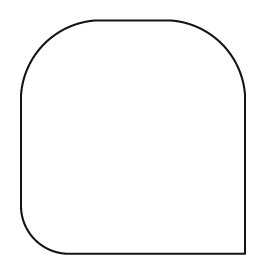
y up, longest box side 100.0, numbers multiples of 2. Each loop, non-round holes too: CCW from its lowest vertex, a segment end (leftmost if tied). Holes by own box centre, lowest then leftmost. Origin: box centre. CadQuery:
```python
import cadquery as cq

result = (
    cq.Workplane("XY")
    .moveTo(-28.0, -50.0)
    .lineTo(48.0, -50.0)
    .lineTo(48.0, 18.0)
    .threePointArc((38.0, 40.0), (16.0, 50.0))
    .lineTo(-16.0, 50.0)
    .threePointArc((-38.0, 40.0), (-48.0, 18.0))
    .lineTo(-48.0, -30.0)
    .threePointArc((-42.0, -44.0), (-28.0, -50.0))
    .close()
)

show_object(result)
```